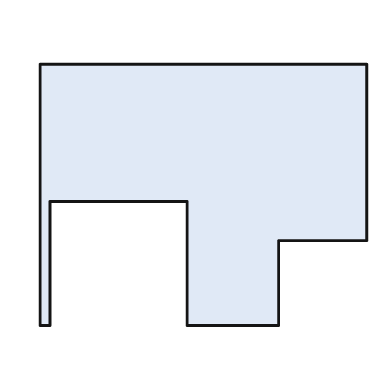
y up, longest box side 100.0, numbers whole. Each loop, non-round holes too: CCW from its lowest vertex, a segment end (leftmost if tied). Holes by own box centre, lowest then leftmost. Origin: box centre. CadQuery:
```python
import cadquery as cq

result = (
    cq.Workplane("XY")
    .moveTo(-50.0, -40.0)
    .lineTo(-47.0, -40.0)
    .lineTo(-47.0, -2.0)
    .lineTo(-5.0, -2.0)
    .lineTo(-5.0, -40.0)
    .lineTo(23.0, -40.0)
    .lineTo(23.0, -14.0)
    .lineTo(50.0, -14.0)
    .lineTo(50.0, 40.0)
    .lineTo(-50.0, 40.0)
    .close()
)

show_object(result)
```